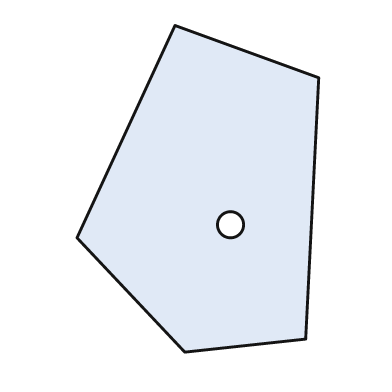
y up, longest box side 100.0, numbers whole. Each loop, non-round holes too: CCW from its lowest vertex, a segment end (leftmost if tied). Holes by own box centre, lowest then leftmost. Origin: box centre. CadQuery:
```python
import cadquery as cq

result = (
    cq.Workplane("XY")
    .moveTo(-4.0, -50.0)
    .lineTo(33.0, -46.0)
    .lineTo(37.0, 34.0)
    .lineTo(-7.0, 50.0)
    .lineTo(-37.0, -15.0)
    .close()
    .moveTo(10.0, -11.0)
    .circle(4.0)
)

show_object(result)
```